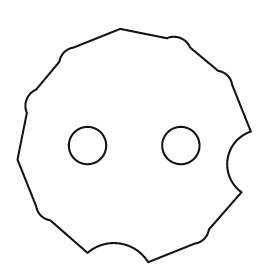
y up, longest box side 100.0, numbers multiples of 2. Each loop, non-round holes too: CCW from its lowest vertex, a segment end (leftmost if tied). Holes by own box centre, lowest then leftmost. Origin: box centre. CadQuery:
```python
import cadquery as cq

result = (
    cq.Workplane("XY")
    .moveTo(6.0, -50.0)
    .lineTo(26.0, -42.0)
    .threePointArc((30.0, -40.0), (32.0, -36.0))
    .lineTo(46.0, -20.0)
    .threePointArc((40.0, -6.0), (50.0, 6.0))
    .lineTo(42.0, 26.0)
    .threePointArc((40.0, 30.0), (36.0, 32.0))
    .lineTo(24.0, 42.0)
    .threePointArc((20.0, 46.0), (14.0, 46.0))
    .lineTo(-6.0, 50.0)
    .lineTo(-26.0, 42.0)
    .threePointArc((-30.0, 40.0), (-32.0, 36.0))
    .lineTo(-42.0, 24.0)
    .threePointArc((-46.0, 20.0), (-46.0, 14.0))
    .lineTo(-50.0, -6.0)
    .lineTo(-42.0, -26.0)
    .threePointArc((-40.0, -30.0), (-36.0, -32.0))
    .lineTo(-20.0, -46.0)
    .threePointArc((-6.0, -42.0), (6.0, -50.0))
    .close()
    .moveTo(-20.0, 0.0)
    .circle(8.0)
    .moveTo(20.0, 0.0)
    .circle(8.0)
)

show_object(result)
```